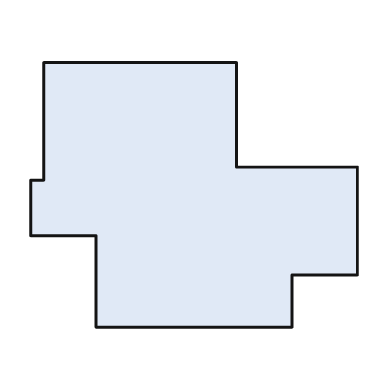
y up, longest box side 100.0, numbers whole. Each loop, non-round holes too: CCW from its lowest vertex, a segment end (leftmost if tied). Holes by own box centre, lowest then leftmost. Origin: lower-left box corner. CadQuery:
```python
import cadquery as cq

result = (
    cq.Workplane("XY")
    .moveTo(20.0, 0.0)
    .lineTo(80.0, 0.0)
    .lineTo(80.0, 16.0)
    .lineTo(100.0, 16.0)
    .lineTo(100.0, 49.0)
    .lineTo(63.0, 49.0)
    .lineTo(63.0, 81.0)
    .lineTo(4.0, 81.0)
    .lineTo(4.0, 45.0)
    .lineTo(0.0, 45.0)
    .lineTo(0.0, 28.0)
    .lineTo(20.0, 28.0)
    .close()
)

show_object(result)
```